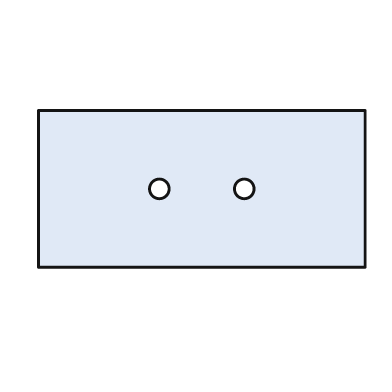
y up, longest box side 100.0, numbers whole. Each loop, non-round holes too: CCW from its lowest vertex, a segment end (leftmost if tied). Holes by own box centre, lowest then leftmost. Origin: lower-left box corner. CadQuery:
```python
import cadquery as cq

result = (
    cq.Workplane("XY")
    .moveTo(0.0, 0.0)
    .lineTo(100.0, 0.0)
    .lineTo(100.0, 48.0)
    .lineTo(0.0, 48.0)
    .close()
    .moveTo(37.0, 24.0)
    .circle(3.0)
    .moveTo(63.0, 24.0)
    .circle(3.0)
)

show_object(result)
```